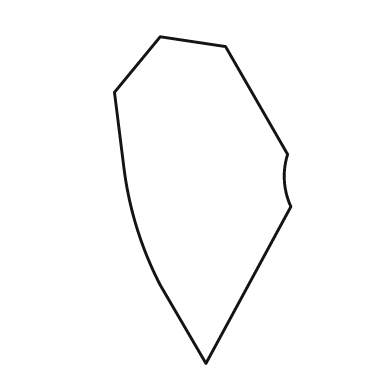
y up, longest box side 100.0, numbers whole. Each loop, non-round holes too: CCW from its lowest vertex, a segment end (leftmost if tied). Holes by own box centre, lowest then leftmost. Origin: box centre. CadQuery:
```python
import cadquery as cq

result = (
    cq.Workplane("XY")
    .moveTo(1.0, -50.0)
    .lineTo(27.0, -2.0)
    .threePointArc((25.0, 6.0), (26.0, 14.0))
    .lineTo(7.0, 47.0)
    .lineTo(-13.0, 50.0)
    .lineTo(-27.0, 33.0)
    .lineTo(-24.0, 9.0)
    .threePointArc((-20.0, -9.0), (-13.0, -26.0))
    .close()
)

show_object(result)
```